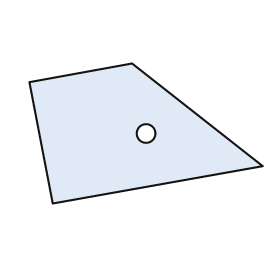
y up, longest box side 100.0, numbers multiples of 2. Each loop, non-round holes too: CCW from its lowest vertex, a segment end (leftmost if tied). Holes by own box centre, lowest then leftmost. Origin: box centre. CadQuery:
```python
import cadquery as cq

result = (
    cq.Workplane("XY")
    .moveTo(-40.0, -30.0)
    .lineTo(50.0, -14.0)
    .lineTo(-6.0, 30.0)
    .lineTo(-50.0, 22.0)
    .close()
    .moveTo(0.0, 0.0)
    .circle(4.0)
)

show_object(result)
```